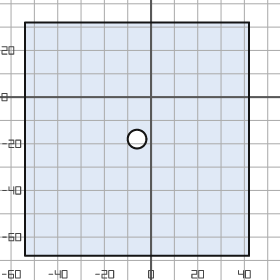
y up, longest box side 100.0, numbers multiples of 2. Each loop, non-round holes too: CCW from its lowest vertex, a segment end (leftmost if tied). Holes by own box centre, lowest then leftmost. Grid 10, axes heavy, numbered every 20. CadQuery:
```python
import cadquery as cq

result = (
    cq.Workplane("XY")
    .moveTo(-54.0, -68.0)
    .lineTo(42.0, -68.0)
    .lineTo(42.0, 32.0)
    .lineTo(-54.0, 32.0)
    .close()
    .moveTo(-6.0, -18.0)
    .circle(4.0)
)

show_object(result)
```